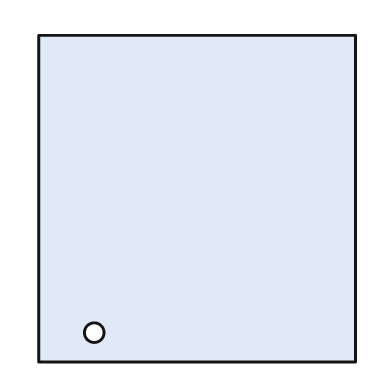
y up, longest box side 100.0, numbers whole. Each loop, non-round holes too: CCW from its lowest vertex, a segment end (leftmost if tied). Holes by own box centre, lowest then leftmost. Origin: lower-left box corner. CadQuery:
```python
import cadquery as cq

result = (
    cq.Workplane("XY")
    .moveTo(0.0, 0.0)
    .lineTo(97.0, 0.0)
    .lineTo(97.0, 100.0)
    .lineTo(0.0, 100.0)
    .close()
    .moveTo(17.0, 9.0)
    .circle(3.0)
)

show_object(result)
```